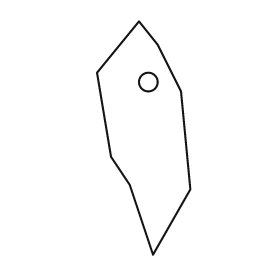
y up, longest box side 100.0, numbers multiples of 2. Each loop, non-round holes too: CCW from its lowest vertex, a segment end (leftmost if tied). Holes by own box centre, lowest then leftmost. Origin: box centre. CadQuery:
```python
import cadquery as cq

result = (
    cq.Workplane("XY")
    .moveTo(4.0, -50.0)
    .lineTo(20.0, -22.0)
    .lineTo(16.0, 20.0)
    .lineTo(6.0, 40.0)
    .lineTo(-2.0, 50.0)
    .lineTo(-20.0, 28.0)
    .lineTo(-14.0, -8.0)
    .lineTo(-6.0, -20.0)
    .close()
    .moveTo(2.0, 24.0)
    .circle(4.0)
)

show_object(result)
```